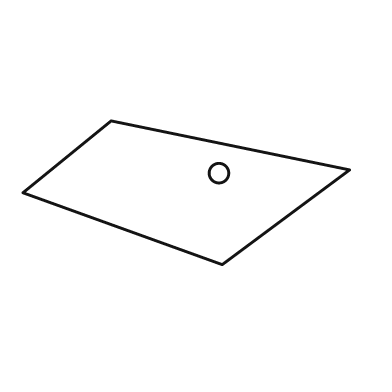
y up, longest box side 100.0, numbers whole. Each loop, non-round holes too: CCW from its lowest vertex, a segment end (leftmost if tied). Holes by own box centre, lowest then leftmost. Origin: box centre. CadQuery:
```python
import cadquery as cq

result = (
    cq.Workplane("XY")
    .moveTo(11.0, -22.0)
    .lineTo(50.0, 7.0)
    .lineTo(-23.0, 22.0)
    .lineTo(-50.0, 0.0)
    .close()
    .moveTo(10.0, 6.0)
    .circle(3.0)
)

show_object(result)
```